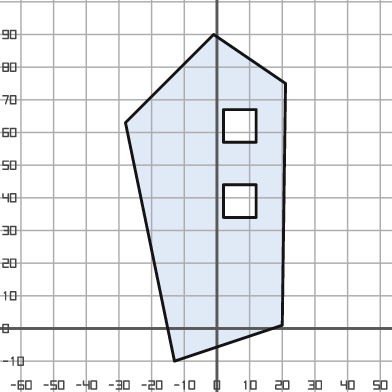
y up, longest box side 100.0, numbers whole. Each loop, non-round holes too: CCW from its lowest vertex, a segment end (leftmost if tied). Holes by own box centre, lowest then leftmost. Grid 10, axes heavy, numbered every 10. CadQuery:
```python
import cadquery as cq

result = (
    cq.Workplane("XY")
    .moveTo(-13.0, -10.0)
    .lineTo(20.0, 1.0)
    .lineTo(21.0, 75.0)
    .lineTo(-1.0, 90.0)
    .lineTo(-28.0, 63.0)
    .close()
    .moveTo(2.0, 34.0)
    .lineTo(12.0, 34.0)
    .lineTo(12.0, 44.0)
    .lineTo(2.0, 44.0)
    .close()
    .moveTo(2.0, 57.0)
    .lineTo(12.0, 57.0)
    .lineTo(12.0, 67.0)
    .lineTo(2.0, 67.0)
    .close()
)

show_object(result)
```